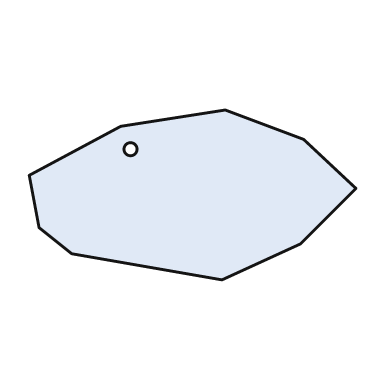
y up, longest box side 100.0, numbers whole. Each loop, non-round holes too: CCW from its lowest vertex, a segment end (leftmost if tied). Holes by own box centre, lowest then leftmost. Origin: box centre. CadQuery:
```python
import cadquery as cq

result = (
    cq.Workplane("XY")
    .moveTo(9.0, -26.0)
    .lineTo(33.0, -15.0)
    .lineTo(50.0, 2.0)
    .lineTo(34.0, 17.0)
    .lineTo(10.0, 26.0)
    .lineTo(-22.0, 21.0)
    .lineTo(-50.0, 6.0)
    .lineTo(-47.0, -10.0)
    .lineTo(-37.0, -18.0)
    .close()
    .moveTo(-19.0, 14.0)
    .circle(2.0)
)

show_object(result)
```